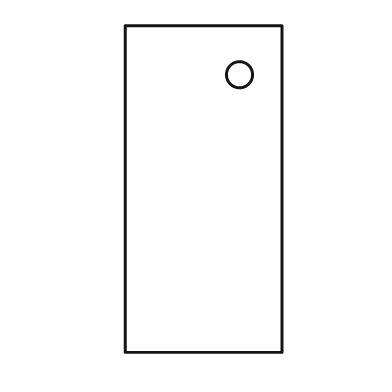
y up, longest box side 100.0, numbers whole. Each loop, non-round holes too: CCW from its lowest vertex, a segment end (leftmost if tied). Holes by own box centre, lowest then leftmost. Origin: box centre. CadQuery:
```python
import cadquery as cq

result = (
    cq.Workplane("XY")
    .moveTo(-24.0, -50.0)
    .lineTo(24.0, -50.0)
    .lineTo(24.0, 50.0)
    .lineTo(-24.0, 50.0)
    .close()
    .moveTo(11.0, 35.0)
    .circle(4.0)
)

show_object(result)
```